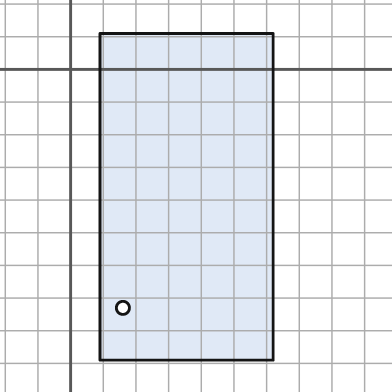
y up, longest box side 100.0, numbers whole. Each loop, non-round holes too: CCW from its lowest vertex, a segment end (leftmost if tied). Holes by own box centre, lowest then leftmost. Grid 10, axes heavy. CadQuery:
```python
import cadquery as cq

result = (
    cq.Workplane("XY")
    .moveTo(9.0, -89.0)
    .lineTo(62.0, -89.0)
    .lineTo(62.0, 11.0)
    .lineTo(9.0, 11.0)
    .close()
    .moveTo(16.0, -73.0)
    .circle(2.0)
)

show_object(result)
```